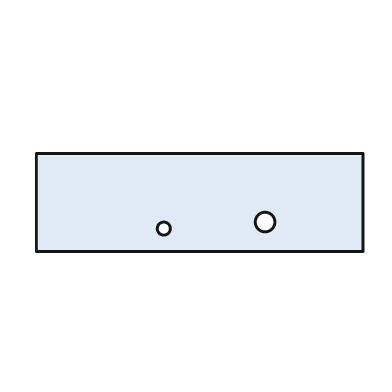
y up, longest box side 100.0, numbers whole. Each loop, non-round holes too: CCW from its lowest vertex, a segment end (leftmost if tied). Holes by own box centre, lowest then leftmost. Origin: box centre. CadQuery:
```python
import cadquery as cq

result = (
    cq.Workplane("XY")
    .moveTo(-50.0, -15.0)
    .lineTo(50.0, -15.0)
    .lineTo(50.0, 15.0)
    .lineTo(-50.0, 15.0)
    .close()
    .moveTo(-11.0, -8.0)
    .circle(2.0)
    .moveTo(20.0, -6.0)
    .circle(3.0)
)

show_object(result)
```